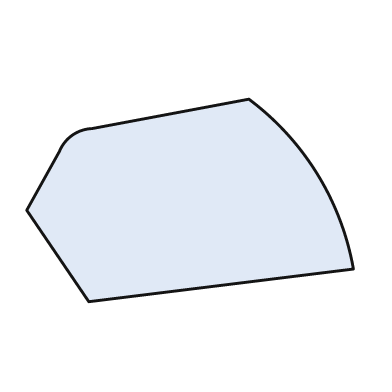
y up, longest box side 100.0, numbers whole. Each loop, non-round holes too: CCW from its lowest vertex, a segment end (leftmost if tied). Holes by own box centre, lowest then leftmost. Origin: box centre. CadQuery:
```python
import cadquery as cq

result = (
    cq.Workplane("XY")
    .moveTo(-31.0, -31.0)
    .lineTo(50.0, -21.0)
    .threePointArc((39.0, 8.0), (18.0, 31.0))
    .lineTo(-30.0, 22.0)
    .threePointArc((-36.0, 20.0), (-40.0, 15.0))
    .lineTo(-50.0, -3.0)
    .close()
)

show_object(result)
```